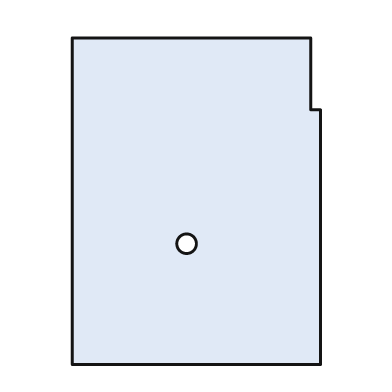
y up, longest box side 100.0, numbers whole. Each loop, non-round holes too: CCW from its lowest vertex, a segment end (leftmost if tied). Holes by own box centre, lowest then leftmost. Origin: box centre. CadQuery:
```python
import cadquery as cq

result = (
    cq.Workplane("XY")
    .moveTo(-38.0, -50.0)
    .lineTo(38.0, -50.0)
    .lineTo(38.0, 28.0)
    .lineTo(35.0, 28.0)
    .lineTo(35.0, 50.0)
    .lineTo(-38.0, 50.0)
    .close()
    .moveTo(-3.0, -13.0)
    .circle(3.0)
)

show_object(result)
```